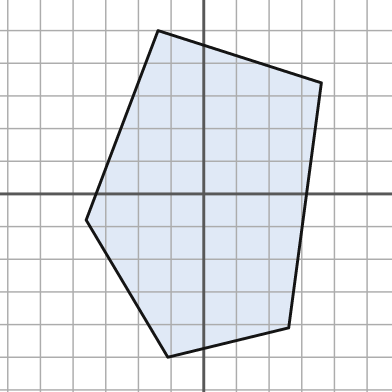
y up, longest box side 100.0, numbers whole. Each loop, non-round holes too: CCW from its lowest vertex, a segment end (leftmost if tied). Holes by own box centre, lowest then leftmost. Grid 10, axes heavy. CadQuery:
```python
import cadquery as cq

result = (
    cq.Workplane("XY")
    .moveTo(-11.0, -50.0)
    .lineTo(26.0, -41.0)
    .lineTo(36.0, 34.0)
    .lineTo(-14.0, 50.0)
    .lineTo(-36.0, -8.0)
    .close()
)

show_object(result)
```